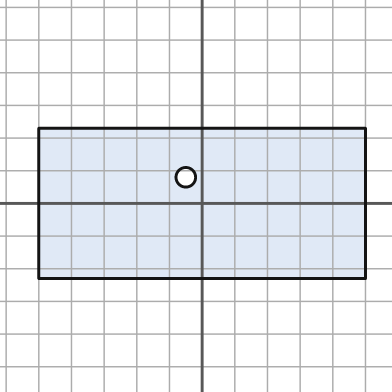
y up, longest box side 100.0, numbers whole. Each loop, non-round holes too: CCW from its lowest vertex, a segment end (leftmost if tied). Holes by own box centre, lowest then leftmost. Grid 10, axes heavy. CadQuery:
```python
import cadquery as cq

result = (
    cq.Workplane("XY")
    .moveTo(-50.0, -23.0)
    .lineTo(50.0, -23.0)
    .lineTo(50.0, 23.0)
    .lineTo(-50.0, 23.0)
    .close()
    .moveTo(-5.0, 8.0)
    .circle(3.0)
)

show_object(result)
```